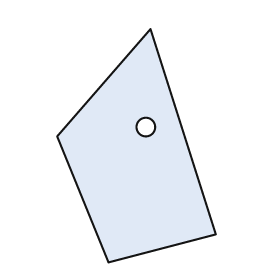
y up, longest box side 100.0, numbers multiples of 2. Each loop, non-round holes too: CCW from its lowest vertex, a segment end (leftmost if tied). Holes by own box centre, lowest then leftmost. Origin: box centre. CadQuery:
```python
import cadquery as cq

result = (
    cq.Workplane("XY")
    .moveTo(-12.0, -50.0)
    .lineTo(34.0, -38.0)
    .lineTo(6.0, 50.0)
    .lineTo(-34.0, 4.0)
    .close()
    .moveTo(4.0, 8.0)
    .circle(4.0)
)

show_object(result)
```